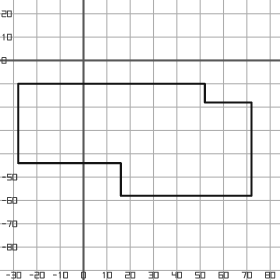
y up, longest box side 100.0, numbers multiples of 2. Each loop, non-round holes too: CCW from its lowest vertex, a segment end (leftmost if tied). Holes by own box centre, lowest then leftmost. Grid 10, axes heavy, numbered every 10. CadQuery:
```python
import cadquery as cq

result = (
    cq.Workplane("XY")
    .moveTo(16.0, -58.0)
    .lineTo(72.0, -58.0)
    .lineTo(72.0, -18.0)
    .lineTo(52.0, -18.0)
    .lineTo(52.0, -10.0)
    .lineTo(-28.0, -10.0)
    .lineTo(-28.0, -44.0)
    .lineTo(16.0, -44.0)
    .close()
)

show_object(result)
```